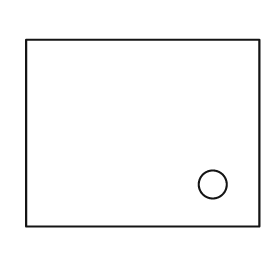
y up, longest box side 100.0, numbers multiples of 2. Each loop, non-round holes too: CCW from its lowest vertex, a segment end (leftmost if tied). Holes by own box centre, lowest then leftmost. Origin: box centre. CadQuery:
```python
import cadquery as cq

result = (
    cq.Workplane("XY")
    .moveTo(-50.0, -40.0)
    .lineTo(50.0, -40.0)
    .lineTo(50.0, 40.0)
    .lineTo(-50.0, 40.0)
    .close()
    .moveTo(30.0, -22.0)
    .circle(6.0)
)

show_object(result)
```